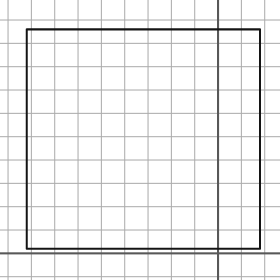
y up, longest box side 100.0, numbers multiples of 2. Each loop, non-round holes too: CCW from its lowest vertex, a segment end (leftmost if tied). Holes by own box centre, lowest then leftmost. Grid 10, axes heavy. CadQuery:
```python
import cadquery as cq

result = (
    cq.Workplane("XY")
    .moveTo(-82.0, 2.0)
    .lineTo(18.0, 2.0)
    .lineTo(18.0, 96.0)
    .lineTo(-82.0, 96.0)
    .close()
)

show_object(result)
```